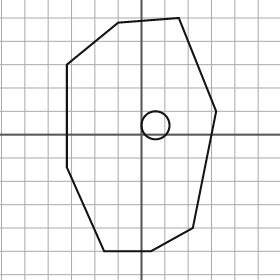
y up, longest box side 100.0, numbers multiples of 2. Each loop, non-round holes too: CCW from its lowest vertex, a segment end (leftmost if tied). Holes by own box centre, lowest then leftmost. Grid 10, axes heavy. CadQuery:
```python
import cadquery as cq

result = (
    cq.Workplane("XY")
    .moveTo(-16.0, -50.0)
    .lineTo(4.0, -50.0)
    .lineTo(22.0, -40.0)
    .lineTo(32.0, 10.0)
    .lineTo(16.0, 50.0)
    .lineTo(-10.0, 48.0)
    .lineTo(-32.0, 30.0)
    .lineTo(-32.0, -14.0)
    .close()
    .moveTo(6.0, 4.0)
    .circle(6.0)
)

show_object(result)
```